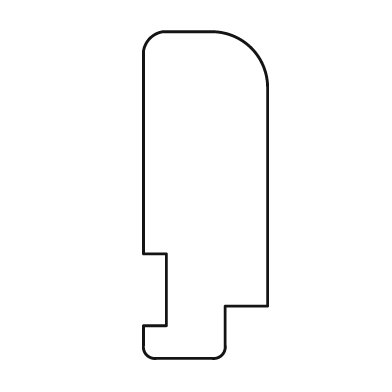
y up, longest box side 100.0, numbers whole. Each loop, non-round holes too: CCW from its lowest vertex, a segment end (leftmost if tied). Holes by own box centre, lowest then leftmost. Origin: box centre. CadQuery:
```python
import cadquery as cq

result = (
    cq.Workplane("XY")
    .moveTo(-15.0, -50.0)
    .lineTo(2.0, -50.0)
    .threePointArc((5.0, -49.0), (6.0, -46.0))
    .lineTo(6.0, -34.0)
    .lineTo(19.0, -34.0)
    .lineTo(19.0, 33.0)
    .threePointArc((14.0, 45.0), (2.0, 50.0))
    .lineTo(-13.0, 50.0)
    .threePointArc((-17.0, 48.0), (-19.0, 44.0))
    .lineTo(-19.0, -18.0)
    .lineTo(-12.0, -18.0)
    .lineTo(-12.0, -40.0)
    .lineTo(-19.0, -40.0)
    .lineTo(-19.0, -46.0)
    .threePointArc((-18.0, -49.0), (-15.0, -50.0))
    .close()
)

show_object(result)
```